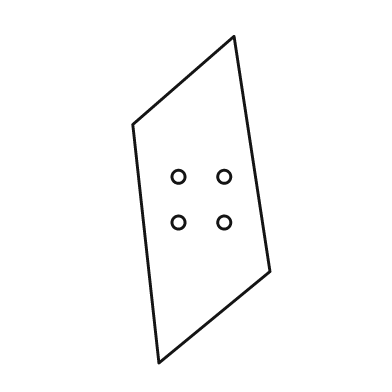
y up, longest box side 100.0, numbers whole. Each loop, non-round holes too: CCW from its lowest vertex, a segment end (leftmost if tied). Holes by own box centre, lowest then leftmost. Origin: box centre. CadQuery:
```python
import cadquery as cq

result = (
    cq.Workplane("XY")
    .moveTo(-13.0, -50.0)
    .lineTo(21.0, -22.0)
    .lineTo(10.0, 50.0)
    .lineTo(-21.0, 23.0)
    .close()
    .moveTo(-7.0, -7.0)
    .circle(2.0)
    .moveTo(7.0, -7.0)
    .circle(2.0)
    .moveTo(-7.0, 7.0)
    .circle(2.0)
    .moveTo(7.0, 7.0)
    .circle(2.0)
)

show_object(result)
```